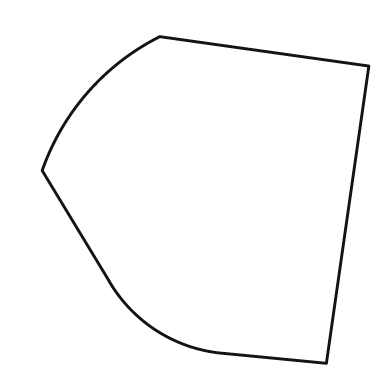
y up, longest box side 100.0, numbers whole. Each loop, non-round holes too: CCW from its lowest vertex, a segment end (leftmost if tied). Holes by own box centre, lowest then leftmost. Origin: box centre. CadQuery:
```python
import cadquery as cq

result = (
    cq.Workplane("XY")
    .moveTo(37.0, -50.0)
    .lineTo(50.0, 41.0)
    .lineTo(-14.0, 50.0)
    .threePointArc((-36.0, 33.0), (-50.0, 9.0))
    .lineTo(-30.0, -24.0)
    .threePointArc((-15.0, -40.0), (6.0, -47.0))
    .close()
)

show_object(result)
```